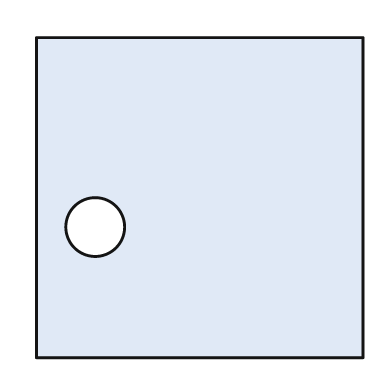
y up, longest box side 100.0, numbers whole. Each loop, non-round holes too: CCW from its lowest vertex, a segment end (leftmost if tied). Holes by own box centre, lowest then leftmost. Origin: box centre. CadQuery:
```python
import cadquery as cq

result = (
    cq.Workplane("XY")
    .moveTo(-50.0, -49.0)
    .lineTo(50.0, -49.0)
    .lineTo(50.0, 49.0)
    .lineTo(-50.0, 49.0)
    .close()
    .moveTo(-32.0, -9.0)
    .circle(9.0)
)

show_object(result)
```